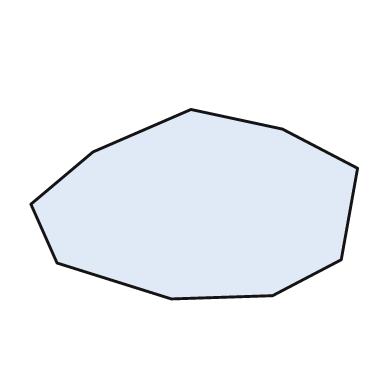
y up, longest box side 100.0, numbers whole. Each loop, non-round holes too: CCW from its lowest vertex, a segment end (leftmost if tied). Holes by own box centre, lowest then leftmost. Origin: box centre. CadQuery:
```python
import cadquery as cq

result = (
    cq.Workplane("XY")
    .moveTo(-7.0, -29.0)
    .lineTo(24.0, -28.0)
    .lineTo(45.0, -17.0)
    .lineTo(50.0, 11.0)
    .lineTo(27.0, 23.0)
    .lineTo(-1.0, 29.0)
    .lineTo(-31.0, 16.0)
    .lineTo(-50.0, 0.0)
    .lineTo(-42.0, -18.0)
    .close()
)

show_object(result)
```